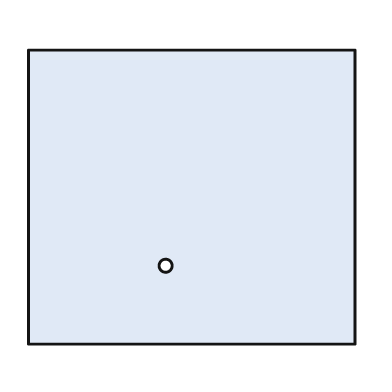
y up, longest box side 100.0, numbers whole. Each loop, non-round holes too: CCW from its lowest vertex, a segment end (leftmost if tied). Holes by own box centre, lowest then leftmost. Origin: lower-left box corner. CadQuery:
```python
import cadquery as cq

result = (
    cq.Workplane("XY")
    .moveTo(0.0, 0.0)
    .lineTo(100.0, 0.0)
    .lineTo(100.0, 90.0)
    .lineTo(0.0, 90.0)
    .close()
    .moveTo(42.0, 24.0)
    .circle(2.0)
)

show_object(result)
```